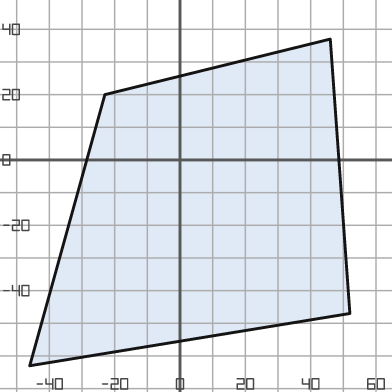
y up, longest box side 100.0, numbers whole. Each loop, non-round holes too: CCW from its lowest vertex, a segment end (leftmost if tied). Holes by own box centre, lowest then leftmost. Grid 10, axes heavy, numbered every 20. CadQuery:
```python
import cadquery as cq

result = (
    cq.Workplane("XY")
    .moveTo(-46.0, -63.0)
    .lineTo(52.0, -47.0)
    .lineTo(46.0, 37.0)
    .lineTo(-23.0, 20.0)
    .close()
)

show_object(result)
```